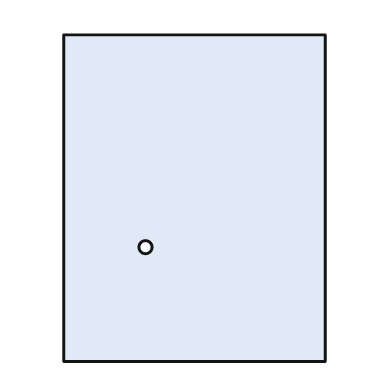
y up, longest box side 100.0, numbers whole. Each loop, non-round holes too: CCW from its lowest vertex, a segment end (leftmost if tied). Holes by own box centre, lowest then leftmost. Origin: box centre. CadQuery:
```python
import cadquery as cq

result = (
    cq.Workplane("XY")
    .moveTo(-40.0, -50.0)
    .lineTo(40.0, -50.0)
    .lineTo(40.0, 50.0)
    .lineTo(-40.0, 50.0)
    .close()
    .moveTo(-15.0, -15.0)
    .circle(2.0)
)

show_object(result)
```